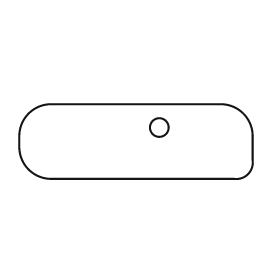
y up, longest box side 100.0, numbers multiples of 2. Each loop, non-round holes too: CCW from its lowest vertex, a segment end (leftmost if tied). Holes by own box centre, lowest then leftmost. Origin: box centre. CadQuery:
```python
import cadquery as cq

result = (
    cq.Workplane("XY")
    .moveTo(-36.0, -16.0)
    .lineTo(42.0, -16.0)
    .threePointArc((48.0, -14.0), (50.0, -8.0))
    .lineTo(50.0, 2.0)
    .threePointArc((46.0, 12.0), (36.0, 16.0))
    .lineTo(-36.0, 16.0)
    .threePointArc((-46.0, 12.0), (-50.0, 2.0))
    .lineTo(-50.0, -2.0)
    .threePointArc((-46.0, -12.0), (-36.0, -16.0))
    .close()
    .moveTo(10.0, 6.0)
    .circle(4.0)
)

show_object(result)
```